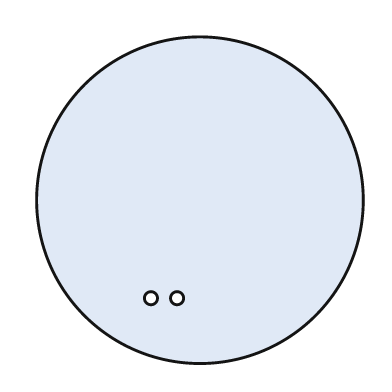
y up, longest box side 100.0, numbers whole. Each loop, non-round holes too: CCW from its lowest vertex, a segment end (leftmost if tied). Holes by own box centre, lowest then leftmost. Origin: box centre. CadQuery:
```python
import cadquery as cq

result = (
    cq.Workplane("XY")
    .moveTo(0.0, 0.0)
    .circle(50.0)
    .moveTo(-15.0, -30.0)
    .circle(2.0)
    .moveTo(-7.0, -30.0)
    .circle(2.0)
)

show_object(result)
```